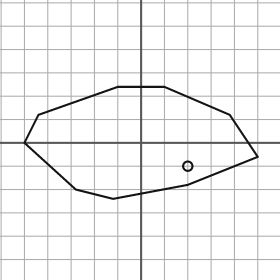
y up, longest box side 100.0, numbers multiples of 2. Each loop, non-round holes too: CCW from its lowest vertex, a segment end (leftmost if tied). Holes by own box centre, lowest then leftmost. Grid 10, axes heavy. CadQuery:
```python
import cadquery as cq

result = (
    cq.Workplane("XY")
    .moveTo(-12.0, -24.0)
    .lineTo(20.0, -18.0)
    .lineTo(50.0, -6.0)
    .lineTo(38.0, 12.0)
    .lineTo(10.0, 24.0)
    .lineTo(-10.0, 24.0)
    .lineTo(-44.0, 12.0)
    .lineTo(-50.0, 0.0)
    .lineTo(-28.0, -20.0)
    .close()
    .moveTo(20.0, -10.0)
    .circle(2.0)
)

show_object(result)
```